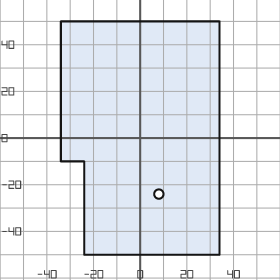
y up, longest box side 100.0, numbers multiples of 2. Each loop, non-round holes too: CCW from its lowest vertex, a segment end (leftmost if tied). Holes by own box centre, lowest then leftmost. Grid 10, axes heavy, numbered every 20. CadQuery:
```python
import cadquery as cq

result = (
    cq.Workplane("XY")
    .moveTo(-24.0, -50.0)
    .lineTo(34.0, -50.0)
    .lineTo(34.0, 50.0)
    .lineTo(-34.0, 50.0)
    .lineTo(-34.0, -10.0)
    .lineTo(-24.0, -10.0)
    .close()
    .moveTo(8.0, -24.0)
    .circle(2.0)
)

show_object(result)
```